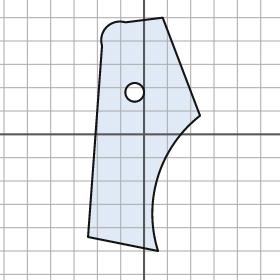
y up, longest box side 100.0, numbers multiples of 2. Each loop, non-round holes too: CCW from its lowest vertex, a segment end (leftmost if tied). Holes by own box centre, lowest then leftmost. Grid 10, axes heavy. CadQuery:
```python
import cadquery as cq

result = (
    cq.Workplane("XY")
    .moveTo(6.0, -50.0)
    .threePointArc((6.0, -18.0), (24.0, 8.0))
    .lineTo(8.0, 50.0)
    .lineTo(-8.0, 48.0)
    .threePointArc((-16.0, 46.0), (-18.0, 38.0))
    .lineTo(-24.0, -44.0)
    .close()
    .moveTo(-4.0, 18.0)
    .circle(4.0)
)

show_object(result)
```